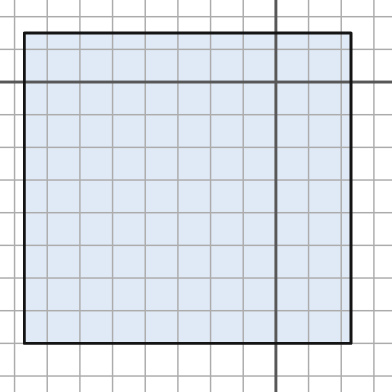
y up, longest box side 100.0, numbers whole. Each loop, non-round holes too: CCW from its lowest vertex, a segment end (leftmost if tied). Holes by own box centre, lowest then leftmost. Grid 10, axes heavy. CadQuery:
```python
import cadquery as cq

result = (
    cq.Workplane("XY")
    .moveTo(-77.0, -80.0)
    .lineTo(23.0, -80.0)
    .lineTo(23.0, 15.0)
    .lineTo(-77.0, 15.0)
    .close()
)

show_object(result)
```